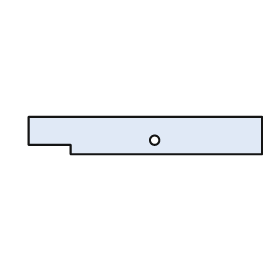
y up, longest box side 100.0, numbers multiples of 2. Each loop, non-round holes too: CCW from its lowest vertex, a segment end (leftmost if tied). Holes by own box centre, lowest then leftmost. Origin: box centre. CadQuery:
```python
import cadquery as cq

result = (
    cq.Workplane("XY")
    .moveTo(-32.0, -8.0)
    .lineTo(50.0, -8.0)
    .lineTo(50.0, 8.0)
    .lineTo(-50.0, 8.0)
    .lineTo(-50.0, -4.0)
    .lineTo(-32.0, -4.0)
    .close()
    .moveTo(4.0, -2.0)
    .circle(2.0)
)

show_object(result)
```